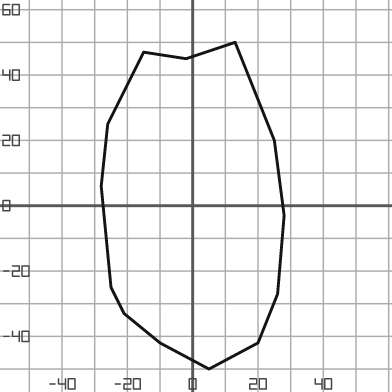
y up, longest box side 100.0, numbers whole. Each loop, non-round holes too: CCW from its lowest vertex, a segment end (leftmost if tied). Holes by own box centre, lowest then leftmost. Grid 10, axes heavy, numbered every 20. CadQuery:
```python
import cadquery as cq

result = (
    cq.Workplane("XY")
    .moveTo(5.0, -50.0)
    .lineTo(20.0, -42.0)
    .lineTo(26.0, -27.0)
    .lineTo(28.0, -3.0)
    .lineTo(25.0, 20.0)
    .lineTo(13.0, 50.0)
    .lineTo(-2.0, 45.0)
    .lineTo(-15.0, 47.0)
    .lineTo(-26.0, 25.0)
    .lineTo(-28.0, 6.0)
    .lineTo(-25.0, -25.0)
    .lineTo(-21.0, -33.0)
    .lineTo(-10.0, -42.0)
    .close()
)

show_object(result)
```